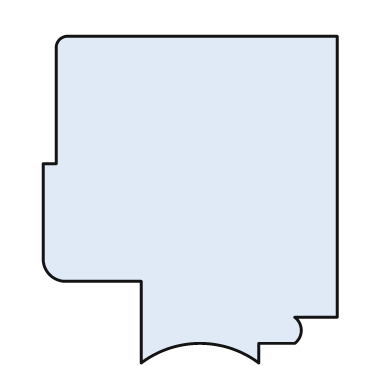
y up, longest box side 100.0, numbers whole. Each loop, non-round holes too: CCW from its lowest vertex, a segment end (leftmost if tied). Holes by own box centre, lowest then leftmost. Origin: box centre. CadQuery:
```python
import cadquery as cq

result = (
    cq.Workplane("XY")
    .moveTo(-15.0, -50.0)
    .threePointArc((3.0, -44.0), (21.0, -50.0))
    .lineTo(21.0, -44.0)
    .lineTo(32.0, -44.0)
    .threePointArc((34.0, -40.0), (32.0, -36.0))
    .lineTo(45.0, -36.0)
    .lineTo(45.0, 50.0)
    .lineTo(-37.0, 50.0)
    .threePointArc((-40.0, 49.0), (-41.0, 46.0))
    .lineTo(-41.0, 11.0)
    .lineTo(-45.0, 11.0)
    .lineTo(-45.0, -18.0)
    .threePointArc((-43.0, -23.0), (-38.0, -25.0))
    .lineTo(-15.0, -25.0)
    .close()
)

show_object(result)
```